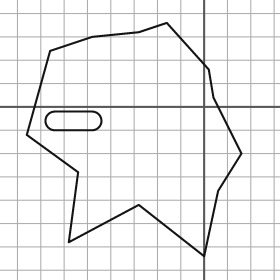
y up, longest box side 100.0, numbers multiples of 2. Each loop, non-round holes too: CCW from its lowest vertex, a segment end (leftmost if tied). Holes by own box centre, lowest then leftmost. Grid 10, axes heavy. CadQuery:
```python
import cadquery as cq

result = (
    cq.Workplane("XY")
    .moveTo(0.0, -64.0)
    .lineTo(6.0, -36.0)
    .lineTo(16.0, -20.0)
    .lineTo(4.0, 4.0)
    .lineTo(2.0, 16.0)
    .lineTo(-16.0, 36.0)
    .lineTo(-28.0, 32.0)
    .lineTo(-48.0, 30.0)
    .lineTo(-66.0, 24.0)
    .lineTo(-76.0, -12.0)
    .lineTo(-54.0, -28.0)
    .lineTo(-58.0, -58.0)
    .lineTo(-28.0, -42.0)
    .close()
    .moveTo(-64.0, -10.0)
    .lineTo(-48.0, -10.0)
    .threePointArc((-44.0, -6.0), (-48.0, -2.0))
    .lineTo(-64.0, -2.0)
    .threePointArc((-68.0, -6.0), (-64.0, -10.0))
    .close()
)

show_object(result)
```